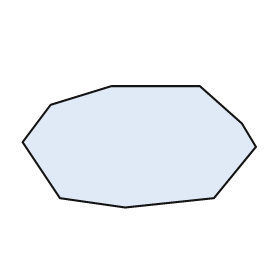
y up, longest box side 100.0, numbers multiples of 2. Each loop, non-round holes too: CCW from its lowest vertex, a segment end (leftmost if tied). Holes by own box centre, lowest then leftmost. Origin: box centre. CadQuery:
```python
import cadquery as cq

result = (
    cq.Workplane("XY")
    .moveTo(-6.0, -26.0)
    .lineTo(32.0, -22.0)
    .lineTo(50.0, 0.0)
    .lineTo(44.0, 10.0)
    .lineTo(26.0, 26.0)
    .lineTo(-12.0, 26.0)
    .lineTo(-38.0, 18.0)
    .lineTo(-50.0, 2.0)
    .lineTo(-34.0, -22.0)
    .close()
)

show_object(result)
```